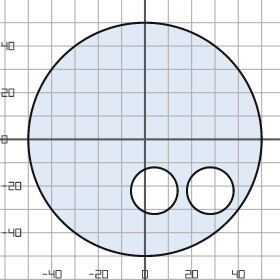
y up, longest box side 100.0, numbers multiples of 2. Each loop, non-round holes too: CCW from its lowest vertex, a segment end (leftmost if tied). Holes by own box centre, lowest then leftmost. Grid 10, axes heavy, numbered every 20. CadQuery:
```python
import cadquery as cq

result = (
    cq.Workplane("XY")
    .moveTo(0.0, 0.0)
    .circle(50.0)
    .moveTo(4.0, -22.0)
    .circle(10.0)
    .moveTo(28.0, -22.0)
    .circle(10.0)
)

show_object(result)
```